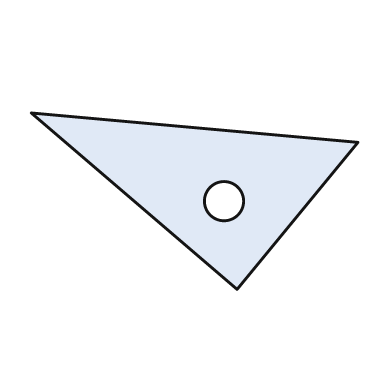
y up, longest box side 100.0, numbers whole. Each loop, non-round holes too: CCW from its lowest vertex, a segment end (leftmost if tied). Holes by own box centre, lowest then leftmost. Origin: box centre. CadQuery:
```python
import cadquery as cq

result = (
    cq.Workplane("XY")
    .moveTo(13.0, -27.0)
    .lineTo(50.0, 18.0)
    .lineTo(-50.0, 27.0)
    .close()
    .moveTo(9.0, 0.0)
    .circle(6.0)
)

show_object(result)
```